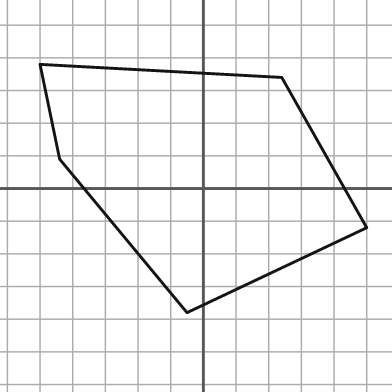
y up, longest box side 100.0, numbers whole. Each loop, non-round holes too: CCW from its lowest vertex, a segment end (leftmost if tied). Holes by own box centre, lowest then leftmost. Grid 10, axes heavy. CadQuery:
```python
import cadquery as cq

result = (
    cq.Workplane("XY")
    .moveTo(-5.0, -38.0)
    .lineTo(50.0, -12.0)
    .lineTo(24.0, 34.0)
    .lineTo(-50.0, 38.0)
    .lineTo(-44.0, 9.0)
    .close()
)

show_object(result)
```